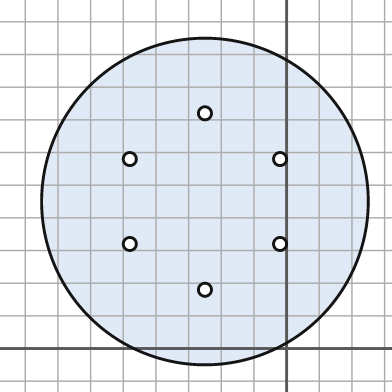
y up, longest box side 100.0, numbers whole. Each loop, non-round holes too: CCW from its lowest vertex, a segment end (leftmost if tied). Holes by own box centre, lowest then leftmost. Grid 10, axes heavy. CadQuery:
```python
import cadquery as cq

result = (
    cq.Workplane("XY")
    .moveTo(-25.0, 45.0)
    .circle(50.0)
    .moveTo(-25.0, 18.0)
    .circle(2.0)
    .moveTo(-48.0, 32.0)
    .circle(2.0)
    .moveTo(-2.0, 32.0)
    .circle(2.0)
    .moveTo(-48.0, 58.0)
    .circle(2.0)
    .moveTo(-2.0, 58.0)
    .circle(2.0)
    .moveTo(-25.0, 72.0)
    .circle(2.0)
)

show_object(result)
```